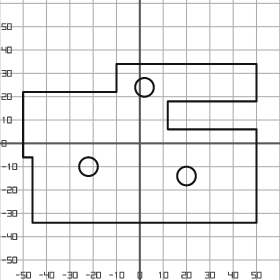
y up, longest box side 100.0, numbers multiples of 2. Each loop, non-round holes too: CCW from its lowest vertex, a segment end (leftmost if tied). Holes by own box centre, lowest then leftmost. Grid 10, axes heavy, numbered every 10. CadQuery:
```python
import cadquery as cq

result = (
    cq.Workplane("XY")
    .moveTo(-46.0, -34.0)
    .lineTo(50.0, -34.0)
    .lineTo(50.0, 6.0)
    .lineTo(12.0, 6.0)
    .lineTo(12.0, 18.0)
    .lineTo(50.0, 18.0)
    .lineTo(50.0, 34.0)
    .lineTo(-10.0, 34.0)
    .lineTo(-10.0, 22.0)
    .lineTo(-50.0, 22.0)
    .lineTo(-50.0, -6.0)
    .lineTo(-46.0, -6.0)
    .close()
    .moveTo(20.0, -14.0)
    .circle(4.0)
    .moveTo(-22.0, -10.0)
    .circle(4.0)
    .moveTo(2.0, 24.0)
    .circle(4.0)
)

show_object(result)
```